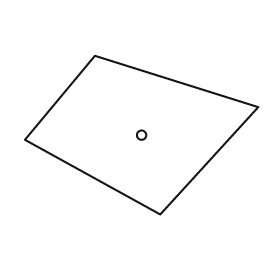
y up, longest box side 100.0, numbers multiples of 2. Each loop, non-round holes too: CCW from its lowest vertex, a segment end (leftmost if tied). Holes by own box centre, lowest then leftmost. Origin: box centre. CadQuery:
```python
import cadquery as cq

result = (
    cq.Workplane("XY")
    .moveTo(8.0, -34.0)
    .lineTo(50.0, 12.0)
    .lineTo(-20.0, 34.0)
    .lineTo(-50.0, -2.0)
    .close()
    .moveTo(0.0, 0.0)
    .circle(2.0)
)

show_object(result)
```